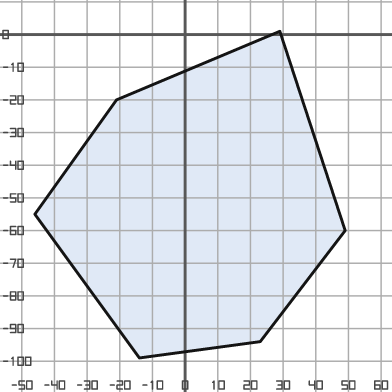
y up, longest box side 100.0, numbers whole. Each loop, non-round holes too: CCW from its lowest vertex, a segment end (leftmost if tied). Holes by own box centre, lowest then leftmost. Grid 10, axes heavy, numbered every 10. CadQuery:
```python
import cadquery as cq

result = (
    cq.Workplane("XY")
    .moveTo(-14.0, -99.0)
    .lineTo(23.0, -94.0)
    .lineTo(49.0, -60.0)
    .lineTo(29.0, 1.0)
    .lineTo(-21.0, -20.0)
    .lineTo(-46.0, -55.0)
    .close()
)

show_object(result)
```